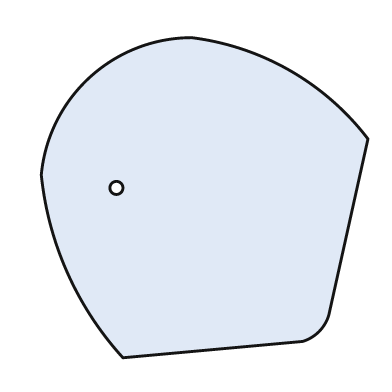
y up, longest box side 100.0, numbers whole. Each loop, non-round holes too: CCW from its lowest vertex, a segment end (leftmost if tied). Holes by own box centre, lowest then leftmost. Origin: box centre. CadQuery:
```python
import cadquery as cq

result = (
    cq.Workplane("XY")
    .moveTo(-25.0, -49.0)
    .lineTo(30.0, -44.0)
    .threePointArc((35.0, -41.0), (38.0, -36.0))
    .lineTo(50.0, 18.0)
    .threePointArc((26.0, 39.0), (-4.0, 49.0))
    .threePointArc((-35.0, 37.0), (-50.0, 7.0))
    .threePointArc((-42.0, -23.0), (-25.0, -49.0))
    .close()
    .moveTo(-27.0, 3.0)
    .circle(2.0)
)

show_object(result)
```